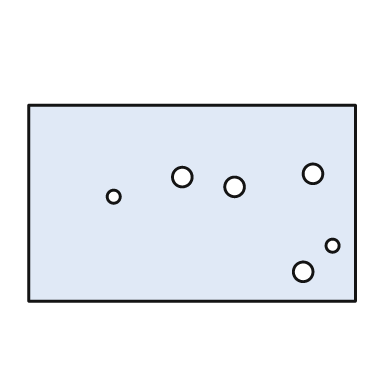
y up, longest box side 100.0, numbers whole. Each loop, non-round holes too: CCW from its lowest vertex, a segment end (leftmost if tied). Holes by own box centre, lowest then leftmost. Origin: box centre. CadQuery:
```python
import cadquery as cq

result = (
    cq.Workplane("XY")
    .moveTo(-50.0, -30.0)
    .lineTo(50.0, -30.0)
    .lineTo(50.0, 30.0)
    .lineTo(-50.0, 30.0)
    .close()
    .moveTo(34.0, -21.0)
    .circle(3.0)
    .moveTo(43.0, -13.0)
    .circle(2.0)
    .moveTo(-24.0, 2.0)
    .circle(2.0)
    .moveTo(13.0, 5.0)
    .circle(3.0)
    .moveTo(-3.0, 8.0)
    .circle(3.0)
    .moveTo(37.0, 9.0)
    .circle(3.0)
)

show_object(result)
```